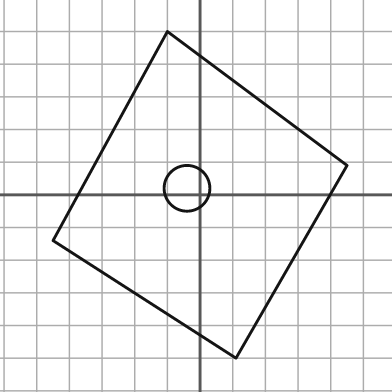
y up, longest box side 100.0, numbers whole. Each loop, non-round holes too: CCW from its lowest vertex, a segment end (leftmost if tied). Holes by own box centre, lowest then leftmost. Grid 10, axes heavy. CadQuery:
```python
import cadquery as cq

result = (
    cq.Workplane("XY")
    .moveTo(11.0, -50.0)
    .lineTo(45.0, 9.0)
    .lineTo(-10.0, 50.0)
    .lineTo(-45.0, -14.0)
    .close()
    .moveTo(-4.0, 2.0)
    .circle(7.0)
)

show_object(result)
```